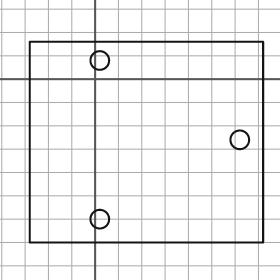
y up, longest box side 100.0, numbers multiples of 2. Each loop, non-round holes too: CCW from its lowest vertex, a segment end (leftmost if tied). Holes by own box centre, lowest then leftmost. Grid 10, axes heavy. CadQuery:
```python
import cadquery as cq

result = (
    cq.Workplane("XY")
    .moveTo(-28.0, -70.0)
    .lineTo(72.0, -70.0)
    .lineTo(72.0, 16.0)
    .lineTo(-28.0, 16.0)
    .close()
    .moveTo(2.0, -60.0)
    .circle(4.0)
    .moveTo(62.0, -26.0)
    .circle(4.0)
    .moveTo(2.0, 8.0)
    .circle(4.0)
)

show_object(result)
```